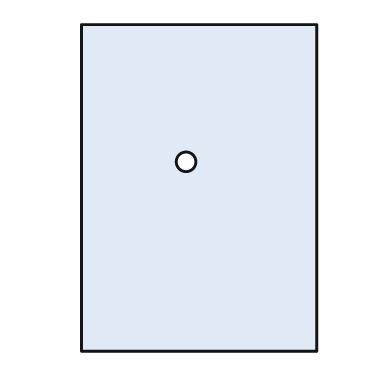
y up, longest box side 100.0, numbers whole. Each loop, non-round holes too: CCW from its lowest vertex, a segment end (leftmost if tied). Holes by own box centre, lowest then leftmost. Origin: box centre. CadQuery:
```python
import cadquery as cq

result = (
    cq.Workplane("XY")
    .moveTo(-36.0, -50.0)
    .lineTo(36.0, -50.0)
    .lineTo(36.0, 50.0)
    .lineTo(-36.0, 50.0)
    .close()
    .moveTo(-4.0, 8.0)
    .circle(3.0)
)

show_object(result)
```